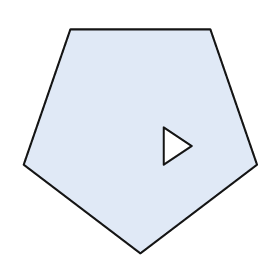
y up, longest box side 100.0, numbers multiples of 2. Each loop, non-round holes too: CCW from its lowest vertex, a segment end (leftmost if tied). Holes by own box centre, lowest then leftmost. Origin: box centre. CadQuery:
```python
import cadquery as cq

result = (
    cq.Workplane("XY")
    .moveTo(0.0, -48.0)
    .lineTo(50.0, -10.0)
    .lineTo(30.0, 48.0)
    .lineTo(-30.0, 48.0)
    .lineTo(-50.0, -10.0)
    .close()
    .moveTo(10.0, -10.0)
    .lineTo(22.0, -2.0)
    .lineTo(10.0, 6.0)
    .close()
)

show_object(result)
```